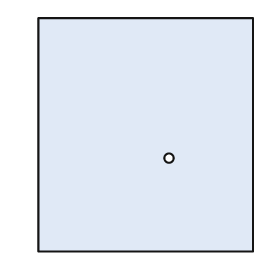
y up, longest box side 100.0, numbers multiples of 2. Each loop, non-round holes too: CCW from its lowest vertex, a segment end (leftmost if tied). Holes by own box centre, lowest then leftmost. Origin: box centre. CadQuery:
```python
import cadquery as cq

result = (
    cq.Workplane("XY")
    .moveTo(-46.0, -50.0)
    .lineTo(46.0, -50.0)
    .lineTo(46.0, 50.0)
    .lineTo(-46.0, 50.0)
    .close()
    .moveTo(10.0, -10.0)
    .circle(2.0)
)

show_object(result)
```